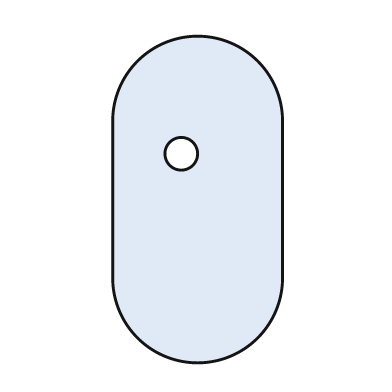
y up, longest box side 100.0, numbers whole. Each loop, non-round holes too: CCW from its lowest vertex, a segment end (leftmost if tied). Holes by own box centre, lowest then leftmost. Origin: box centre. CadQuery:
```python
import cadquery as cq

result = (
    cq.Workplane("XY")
    .moveTo(-26.0, -24.0)
    .threePointArc((0.0, -50.0), (26.0, -24.0))
    .lineTo(26.0, 24.0)
    .threePointArc((0.0, 50.0), (-26.0, 24.0))
    .close()
    .moveTo(-5.0, 14.0)
    .circle(5.0)
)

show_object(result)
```